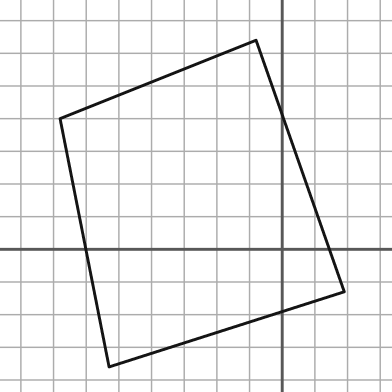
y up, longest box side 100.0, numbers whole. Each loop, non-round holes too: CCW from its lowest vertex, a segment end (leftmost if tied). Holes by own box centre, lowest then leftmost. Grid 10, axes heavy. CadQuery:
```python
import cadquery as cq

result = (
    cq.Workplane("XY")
    .moveTo(-53.0, -36.0)
    .lineTo(19.0, -13.0)
    .lineTo(-8.0, 64.0)
    .lineTo(-68.0, 40.0)
    .close()
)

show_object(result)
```